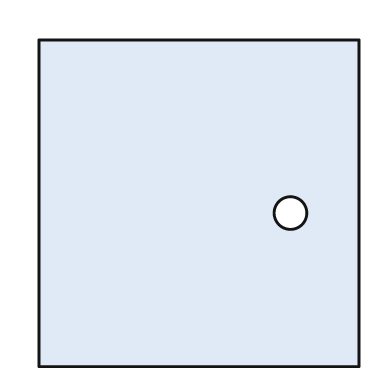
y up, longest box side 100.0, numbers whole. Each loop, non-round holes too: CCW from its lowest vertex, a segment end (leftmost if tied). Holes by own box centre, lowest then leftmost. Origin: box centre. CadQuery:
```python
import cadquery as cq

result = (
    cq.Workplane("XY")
    .moveTo(-49.0, -50.0)
    .lineTo(49.0, -50.0)
    .lineTo(49.0, 50.0)
    .lineTo(-49.0, 50.0)
    .close()
    .moveTo(28.0, -3.0)
    .circle(5.0)
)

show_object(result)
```